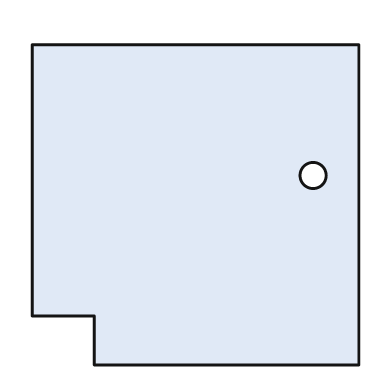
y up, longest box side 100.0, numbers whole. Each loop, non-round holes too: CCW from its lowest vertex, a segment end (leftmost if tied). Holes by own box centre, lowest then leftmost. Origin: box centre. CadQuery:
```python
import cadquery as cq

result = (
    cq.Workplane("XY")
    .moveTo(-31.0, -49.0)
    .lineTo(50.0, -49.0)
    .lineTo(50.0, 49.0)
    .lineTo(-50.0, 49.0)
    .lineTo(-50.0, -34.0)
    .lineTo(-31.0, -34.0)
    .close()
    .moveTo(36.0, 9.0)
    .circle(4.0)
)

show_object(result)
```